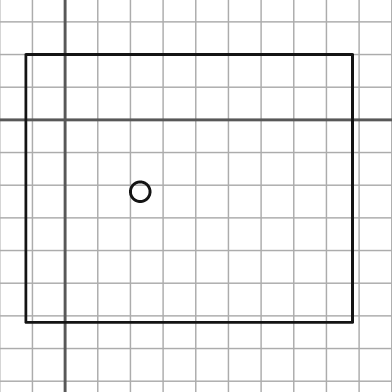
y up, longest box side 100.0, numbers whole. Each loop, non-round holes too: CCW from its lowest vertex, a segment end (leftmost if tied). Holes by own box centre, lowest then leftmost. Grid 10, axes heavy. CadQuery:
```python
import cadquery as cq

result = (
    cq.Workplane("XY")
    .moveTo(-12.0, -62.0)
    .lineTo(88.0, -62.0)
    .lineTo(88.0, 20.0)
    .lineTo(-12.0, 20.0)
    .close()
    .moveTo(23.0, -22.0)
    .circle(3.0)
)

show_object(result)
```